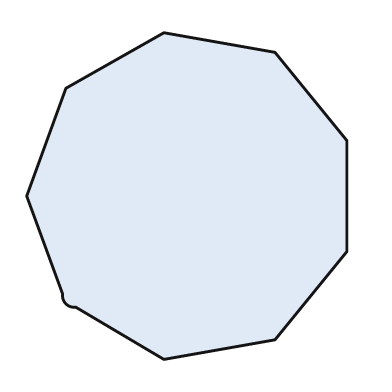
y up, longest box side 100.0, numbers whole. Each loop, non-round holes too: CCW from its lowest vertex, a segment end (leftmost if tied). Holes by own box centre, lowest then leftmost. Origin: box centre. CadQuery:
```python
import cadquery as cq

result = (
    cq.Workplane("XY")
    .moveTo(-7.0, -50.0)
    .lineTo(27.0, -44.0)
    .lineTo(49.0, -17.0)
    .lineTo(49.0, 17.0)
    .lineTo(27.0, 44.0)
    .lineTo(-7.0, 50.0)
    .lineTo(-37.0, 33.0)
    .lineTo(-49.0, 0.0)
    .lineTo(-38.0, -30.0)
    .threePointArc((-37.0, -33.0), (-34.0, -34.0))
    .close()
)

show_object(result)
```